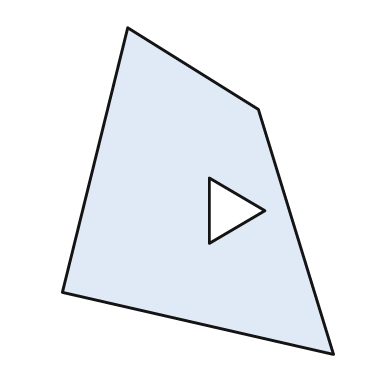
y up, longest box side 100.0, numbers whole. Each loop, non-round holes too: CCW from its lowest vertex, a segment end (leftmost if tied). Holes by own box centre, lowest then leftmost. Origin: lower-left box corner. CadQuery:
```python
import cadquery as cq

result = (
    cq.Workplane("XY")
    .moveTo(83.0, 0.0)
    .lineTo(60.0, 75.0)
    .lineTo(20.0, 100.0)
    .lineTo(0.0, 19.0)
    .close()
    .moveTo(45.0, 34.0)
    .lineTo(62.0, 44.0)
    .lineTo(45.0, 54.0)
    .close()
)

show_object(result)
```